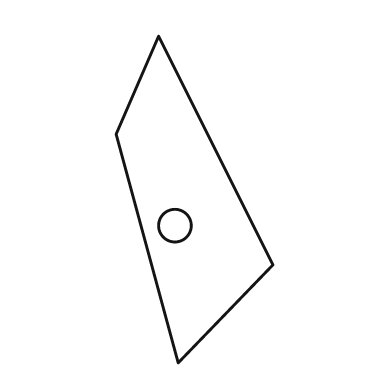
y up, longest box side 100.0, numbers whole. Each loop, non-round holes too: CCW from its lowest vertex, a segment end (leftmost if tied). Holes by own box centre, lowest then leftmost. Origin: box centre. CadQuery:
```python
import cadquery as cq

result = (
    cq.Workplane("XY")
    .moveTo(-5.0, -50.0)
    .lineTo(24.0, -20.0)
    .lineTo(-11.0, 50.0)
    .lineTo(-24.0, 20.0)
    .close()
    .moveTo(-6.0, -8.0)
    .circle(5.0)
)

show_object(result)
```